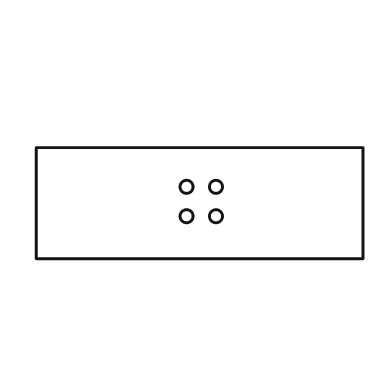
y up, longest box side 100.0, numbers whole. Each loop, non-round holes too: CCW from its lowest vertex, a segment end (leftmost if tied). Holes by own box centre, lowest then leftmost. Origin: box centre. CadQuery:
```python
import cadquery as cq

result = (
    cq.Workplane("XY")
    .moveTo(-50.0, -17.0)
    .lineTo(50.0, -17.0)
    .lineTo(50.0, 17.0)
    .lineTo(-50.0, 17.0)
    .close()
    .moveTo(-4.0, -4.0)
    .circle(2.0)
    .moveTo(5.0, -4.0)
    .circle(2.0)
    .moveTo(-4.0, 5.0)
    .circle(2.0)
    .moveTo(5.0, 5.0)
    .circle(2.0)
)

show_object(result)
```